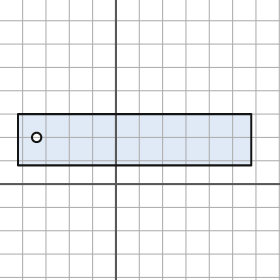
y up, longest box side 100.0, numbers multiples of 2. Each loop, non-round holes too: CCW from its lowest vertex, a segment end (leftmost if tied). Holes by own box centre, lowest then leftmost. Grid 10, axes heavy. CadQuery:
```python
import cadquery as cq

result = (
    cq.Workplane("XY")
    .moveTo(-42.0, 8.0)
    .lineTo(58.0, 8.0)
    .lineTo(58.0, 30.0)
    .lineTo(-42.0, 30.0)
    .close()
    .moveTo(-34.0, 20.0)
    .circle(2.0)
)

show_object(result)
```